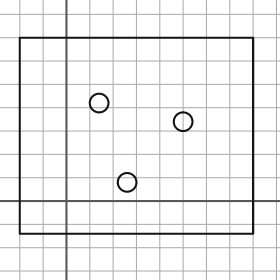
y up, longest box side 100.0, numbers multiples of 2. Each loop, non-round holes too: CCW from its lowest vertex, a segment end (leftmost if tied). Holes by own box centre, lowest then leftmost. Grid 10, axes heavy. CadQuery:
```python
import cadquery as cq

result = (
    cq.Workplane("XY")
    .moveTo(-20.0, -14.0)
    .lineTo(80.0, -14.0)
    .lineTo(80.0, 70.0)
    .lineTo(-20.0, 70.0)
    .close()
    .moveTo(26.0, 8.0)
    .circle(4.0)
    .moveTo(50.0, 34.0)
    .circle(4.0)
    .moveTo(14.0, 42.0)
    .circle(4.0)
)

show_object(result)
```